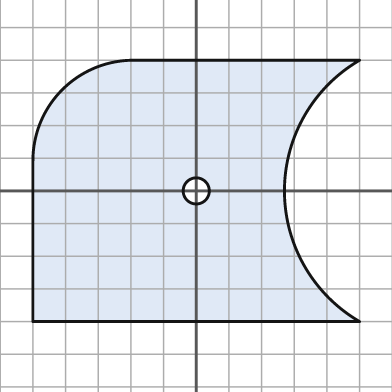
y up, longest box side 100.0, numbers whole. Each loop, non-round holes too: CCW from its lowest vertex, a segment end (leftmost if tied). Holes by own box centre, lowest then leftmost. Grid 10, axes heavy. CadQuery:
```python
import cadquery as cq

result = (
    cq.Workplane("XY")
    .moveTo(-50.0, -40.0)
    .lineTo(50.0, -40.0)
    .threePointArc((27.0, 0.0), (50.0, 40.0))
    .lineTo(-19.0, 40.0)
    .threePointArc((-41.0, 31.0), (-50.0, 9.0))
    .close()
    .moveTo(0.0, 0.0)
    .circle(4.0)
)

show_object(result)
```